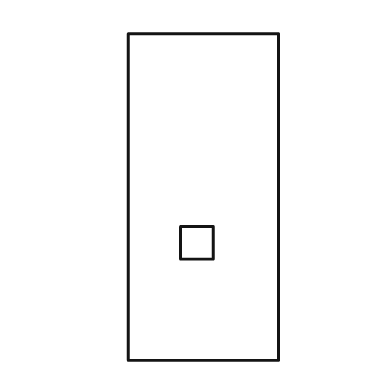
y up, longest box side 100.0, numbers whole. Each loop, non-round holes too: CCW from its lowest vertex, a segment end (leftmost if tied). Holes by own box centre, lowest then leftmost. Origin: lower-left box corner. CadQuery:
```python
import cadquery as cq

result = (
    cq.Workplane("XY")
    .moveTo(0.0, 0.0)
    .lineTo(46.0, 0.0)
    .lineTo(46.0, 100.0)
    .lineTo(0.0, 100.0)
    .close()
    .moveTo(16.0, 31.0)
    .lineTo(26.0, 31.0)
    .lineTo(26.0, 41.0)
    .lineTo(16.0, 41.0)
    .close()
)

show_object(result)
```